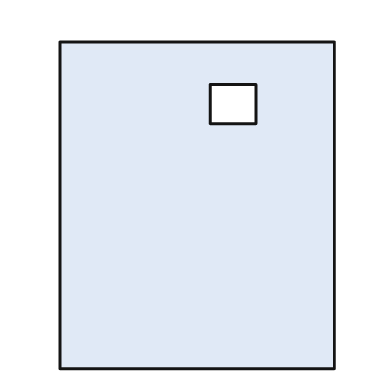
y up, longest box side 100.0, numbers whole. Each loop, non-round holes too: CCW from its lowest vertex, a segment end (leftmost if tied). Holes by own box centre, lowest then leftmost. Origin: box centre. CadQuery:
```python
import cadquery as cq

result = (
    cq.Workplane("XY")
    .moveTo(-42.0, -50.0)
    .lineTo(42.0, -50.0)
    .lineTo(42.0, 50.0)
    .lineTo(-42.0, 50.0)
    .close()
    .moveTo(4.0, 25.0)
    .lineTo(18.0, 25.0)
    .lineTo(18.0, 37.0)
    .lineTo(4.0, 37.0)
    .close()
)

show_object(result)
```